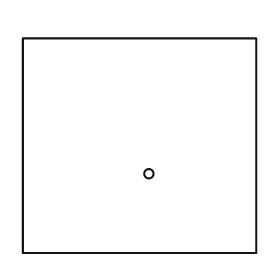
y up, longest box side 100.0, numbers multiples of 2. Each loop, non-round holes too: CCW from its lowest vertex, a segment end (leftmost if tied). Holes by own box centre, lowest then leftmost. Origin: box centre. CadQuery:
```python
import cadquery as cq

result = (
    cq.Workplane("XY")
    .moveTo(-50.0, -46.0)
    .lineTo(50.0, -46.0)
    .lineTo(50.0, 46.0)
    .lineTo(-50.0, 46.0)
    .close()
    .moveTo(4.0, -12.0)
    .circle(2.0)
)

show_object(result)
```